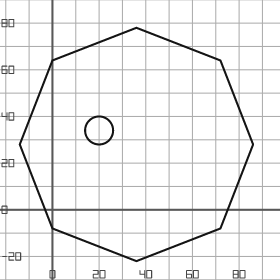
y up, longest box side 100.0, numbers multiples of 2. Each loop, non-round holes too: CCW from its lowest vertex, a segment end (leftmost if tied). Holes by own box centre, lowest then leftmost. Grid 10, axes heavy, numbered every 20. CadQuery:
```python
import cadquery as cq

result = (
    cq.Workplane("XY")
    .moveTo(36.0, -22.0)
    .lineTo(72.0, -8.0)
    .lineTo(86.0, 28.0)
    .lineTo(72.0, 64.0)
    .lineTo(36.0, 78.0)
    .lineTo(0.0, 64.0)
    .lineTo(-14.0, 28.0)
    .lineTo(0.0, -8.0)
    .close()
    .moveTo(20.0, 34.0)
    .circle(6.0)
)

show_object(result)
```